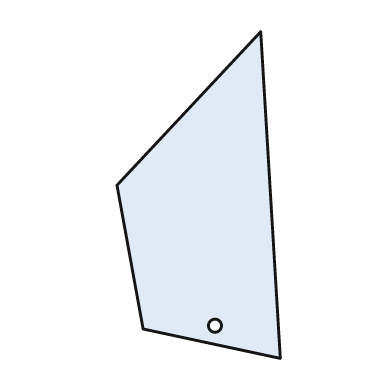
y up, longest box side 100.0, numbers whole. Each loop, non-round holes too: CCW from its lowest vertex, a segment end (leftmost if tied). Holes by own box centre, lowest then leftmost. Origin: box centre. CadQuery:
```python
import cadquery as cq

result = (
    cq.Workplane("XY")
    .moveTo(25.0, -50.0)
    .lineTo(19.0, 50.0)
    .lineTo(-25.0, 3.0)
    .lineTo(-17.0, -41.0)
    .close()
    .moveTo(5.0, -40.0)
    .circle(2.0)
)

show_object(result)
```